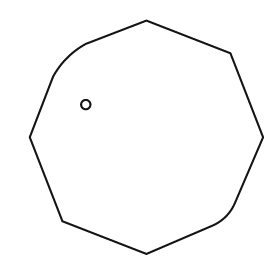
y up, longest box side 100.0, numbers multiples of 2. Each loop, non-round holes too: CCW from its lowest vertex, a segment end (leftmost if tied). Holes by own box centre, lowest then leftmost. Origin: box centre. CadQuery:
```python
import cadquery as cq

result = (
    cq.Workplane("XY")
    .moveTo(0.0, -50.0)
    .lineTo(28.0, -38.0)
    .threePointArc((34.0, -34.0), (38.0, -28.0))
    .lineTo(50.0, 0.0)
    .lineTo(36.0, 36.0)
    .lineTo(0.0, 50.0)
    .lineTo(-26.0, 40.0)
    .threePointArc((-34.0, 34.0), (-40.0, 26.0))
    .lineTo(-50.0, 0.0)
    .lineTo(-36.0, -36.0)
    .close()
    .moveTo(-26.0, 14.0)
    .circle(2.0)
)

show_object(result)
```